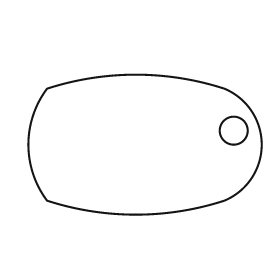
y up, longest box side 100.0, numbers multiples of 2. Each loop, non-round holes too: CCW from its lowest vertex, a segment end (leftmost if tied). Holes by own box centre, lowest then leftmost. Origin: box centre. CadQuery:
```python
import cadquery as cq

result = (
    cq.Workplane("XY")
    .moveTo(-42.0, -24.0)
    .threePointArc((-4.0, -30.0), (34.0, -24.0))
    .threePointArc((50.0, 0.0), (34.0, 24.0))
    .threePointArc((-4.0, 30.0), (-42.0, 24.0))
    .threePointArc((-50.0, 0.0), (-42.0, -24.0))
    .close()
    .moveTo(38.0, 6.0)
    .circle(6.0)
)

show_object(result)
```